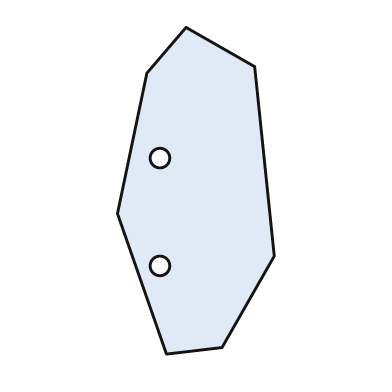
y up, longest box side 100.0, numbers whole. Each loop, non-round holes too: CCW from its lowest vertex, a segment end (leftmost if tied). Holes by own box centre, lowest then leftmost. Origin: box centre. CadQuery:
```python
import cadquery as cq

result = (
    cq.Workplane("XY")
    .moveTo(-9.0, -50.0)
    .lineTo(8.0, -48.0)
    .lineTo(24.0, -20.0)
    .lineTo(18.0, 38.0)
    .lineTo(-3.0, 50.0)
    .lineTo(-15.0, 36.0)
    .lineTo(-24.0, -7.0)
    .close()
    .moveTo(-11.0, -23.0)
    .circle(3.0)
    .moveTo(-11.0, 10.0)
    .circle(3.0)
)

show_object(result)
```